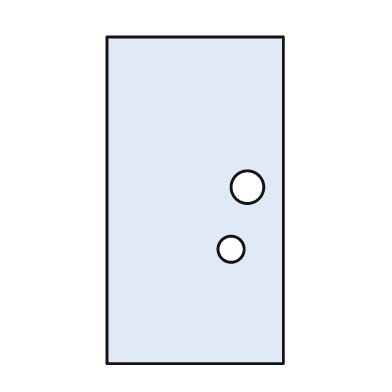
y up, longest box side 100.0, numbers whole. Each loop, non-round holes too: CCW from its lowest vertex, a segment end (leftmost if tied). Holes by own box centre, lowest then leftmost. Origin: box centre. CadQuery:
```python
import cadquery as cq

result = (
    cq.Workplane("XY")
    .moveTo(-27.0, -50.0)
    .lineTo(27.0, -50.0)
    .lineTo(27.0, 50.0)
    .lineTo(-27.0, 50.0)
    .close()
    .moveTo(11.0, -15.0)
    .circle(4.0)
    .moveTo(16.0, 4.0)
    .circle(5.0)
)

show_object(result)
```